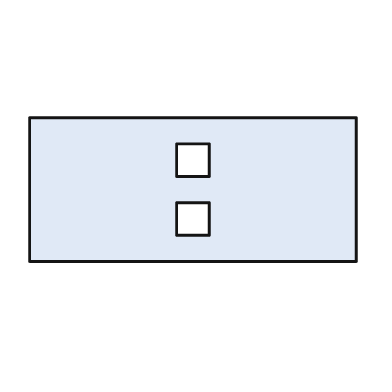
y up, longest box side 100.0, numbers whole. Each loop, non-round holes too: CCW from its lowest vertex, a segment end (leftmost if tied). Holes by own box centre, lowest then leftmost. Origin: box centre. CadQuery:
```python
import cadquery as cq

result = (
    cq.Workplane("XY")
    .moveTo(-50.0, -22.0)
    .lineTo(50.0, -22.0)
    .lineTo(50.0, 22.0)
    .lineTo(-50.0, 22.0)
    .close()
    .moveTo(-5.0, -14.0)
    .lineTo(5.0, -14.0)
    .lineTo(5.0, -4.0)
    .lineTo(-5.0, -4.0)
    .close()
    .moveTo(-5.0, 4.0)
    .lineTo(5.0, 4.0)
    .lineTo(5.0, 14.0)
    .lineTo(-5.0, 14.0)
    .close()
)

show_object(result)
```